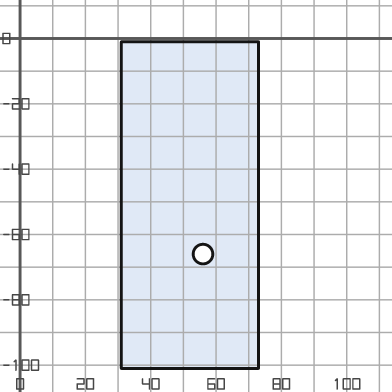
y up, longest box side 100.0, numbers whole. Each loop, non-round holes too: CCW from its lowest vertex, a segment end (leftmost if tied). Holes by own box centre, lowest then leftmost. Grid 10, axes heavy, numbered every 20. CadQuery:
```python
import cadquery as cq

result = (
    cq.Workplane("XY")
    .moveTo(31.0, -101.0)
    .lineTo(73.0, -101.0)
    .lineTo(73.0, -1.0)
    .lineTo(31.0, -1.0)
    .close()
    .moveTo(56.0, -66.0)
    .circle(3.0)
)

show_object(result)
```